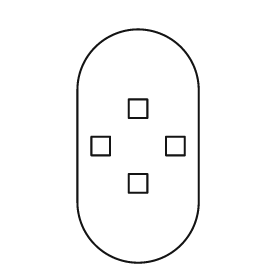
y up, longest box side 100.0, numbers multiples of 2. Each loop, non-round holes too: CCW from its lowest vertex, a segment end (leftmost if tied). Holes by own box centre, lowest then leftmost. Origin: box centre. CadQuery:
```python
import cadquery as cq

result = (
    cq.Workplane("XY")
    .moveTo(-26.0, -24.0)
    .threePointArc((0.0, -50.0), (26.0, -24.0))
    .lineTo(26.0, 24.0)
    .threePointArc((0.0, 50.0), (-26.0, 24.0))
    .close()
    .moveTo(-4.0, -20.0)
    .lineTo(4.0, -20.0)
    .lineTo(4.0, -12.0)
    .lineTo(-4.0, -12.0)
    .close()
    .moveTo(-20.0, -4.0)
    .lineTo(-12.0, -4.0)
    .lineTo(-12.0, 4.0)
    .lineTo(-20.0, 4.0)
    .close()
    .moveTo(12.0, -4.0)
    .lineTo(20.0, -4.0)
    .lineTo(20.0, 4.0)
    .lineTo(12.0, 4.0)
    .close()
    .moveTo(-4.0, 12.0)
    .lineTo(4.0, 12.0)
    .lineTo(4.0, 20.0)
    .lineTo(-4.0, 20.0)
    .close()
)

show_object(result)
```